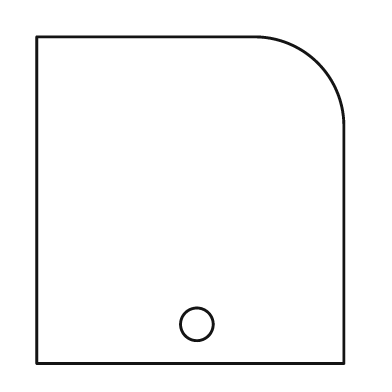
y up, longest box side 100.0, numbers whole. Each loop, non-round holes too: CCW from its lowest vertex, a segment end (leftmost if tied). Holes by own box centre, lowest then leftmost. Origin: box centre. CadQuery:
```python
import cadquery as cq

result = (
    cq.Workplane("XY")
    .moveTo(-47.0, -50.0)
    .lineTo(47.0, -50.0)
    .lineTo(47.0, 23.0)
    .threePointArc((39.0, 42.0), (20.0, 50.0))
    .lineTo(-47.0, 50.0)
    .close()
    .moveTo(2.0, -38.0)
    .circle(5.0)
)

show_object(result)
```